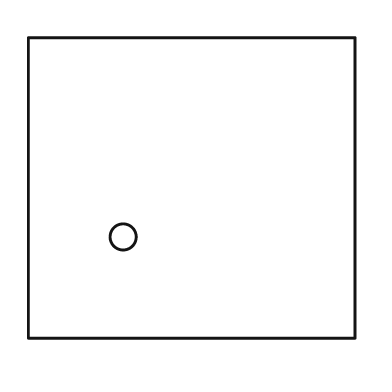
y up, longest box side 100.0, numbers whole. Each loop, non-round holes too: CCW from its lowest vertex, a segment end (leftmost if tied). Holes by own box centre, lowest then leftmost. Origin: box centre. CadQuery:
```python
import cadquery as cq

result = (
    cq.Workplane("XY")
    .moveTo(-50.0, -46.0)
    .lineTo(50.0, -46.0)
    .lineTo(50.0, 46.0)
    .lineTo(-50.0, 46.0)
    .close()
    .moveTo(-21.0, -15.0)
    .circle(4.0)
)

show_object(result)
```